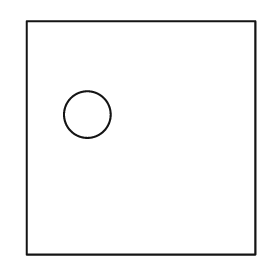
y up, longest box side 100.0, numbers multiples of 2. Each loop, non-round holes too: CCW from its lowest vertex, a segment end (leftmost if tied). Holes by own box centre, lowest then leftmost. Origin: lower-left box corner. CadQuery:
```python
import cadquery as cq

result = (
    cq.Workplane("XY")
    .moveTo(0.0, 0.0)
    .lineTo(98.0, 0.0)
    .lineTo(98.0, 100.0)
    .lineTo(0.0, 100.0)
    .close()
    .moveTo(26.0, 60.0)
    .circle(10.0)
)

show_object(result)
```